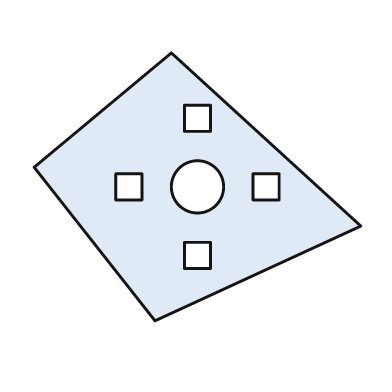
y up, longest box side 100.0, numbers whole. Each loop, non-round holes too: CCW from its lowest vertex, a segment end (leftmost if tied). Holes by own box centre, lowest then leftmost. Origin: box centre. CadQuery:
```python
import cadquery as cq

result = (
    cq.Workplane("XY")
    .moveTo(-13.0, -41.0)
    .lineTo(50.0, -12.0)
    .lineTo(-8.0, 41.0)
    .lineTo(-50.0, 6.0)
    .close()
    .moveTo(-4.0, -25.0)
    .lineTo(4.0, -25.0)
    .lineTo(4.0, -17.0)
    .lineTo(-4.0, -17.0)
    .close()
    .moveTo(-25.0, -4.0)
    .lineTo(-17.0, -4.0)
    .lineTo(-17.0, 4.0)
    .lineTo(-25.0, 4.0)
    .close()
    .moveTo(0.0, 0.0)
    .circle(8.0)
    .moveTo(17.0, -4.0)
    .lineTo(25.0, -4.0)
    .lineTo(25.0, 4.0)
    .lineTo(17.0, 4.0)
    .close()
    .moveTo(-4.0, 17.0)
    .lineTo(4.0, 17.0)
    .lineTo(4.0, 25.0)
    .lineTo(-4.0, 25.0)
    .close()
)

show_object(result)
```